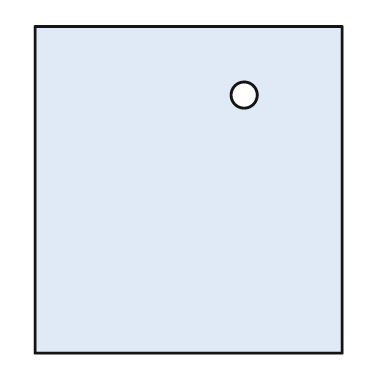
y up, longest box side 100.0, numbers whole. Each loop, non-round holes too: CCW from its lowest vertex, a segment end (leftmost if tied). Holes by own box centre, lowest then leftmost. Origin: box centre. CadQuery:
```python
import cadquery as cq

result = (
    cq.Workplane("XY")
    .moveTo(-47.0, -50.0)
    .lineTo(47.0, -50.0)
    .lineTo(47.0, 50.0)
    .lineTo(-47.0, 50.0)
    .close()
    .moveTo(17.0, 29.0)
    .circle(4.0)
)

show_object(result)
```